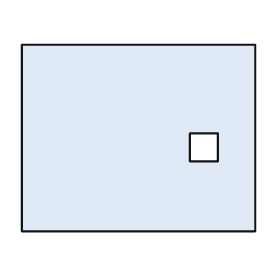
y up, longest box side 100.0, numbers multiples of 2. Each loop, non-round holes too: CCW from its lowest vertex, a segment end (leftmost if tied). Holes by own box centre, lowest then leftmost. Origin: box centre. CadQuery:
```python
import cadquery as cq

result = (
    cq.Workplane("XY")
    .moveTo(-50.0, -40.0)
    .lineTo(50.0, -40.0)
    .lineTo(50.0, 40.0)
    .lineTo(-50.0, 40.0)
    .close()
    .moveTo(22.0, -10.0)
    .lineTo(34.0, -10.0)
    .lineTo(34.0, 2.0)
    .lineTo(22.0, 2.0)
    .close()
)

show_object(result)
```